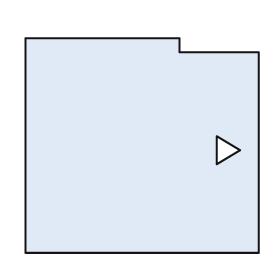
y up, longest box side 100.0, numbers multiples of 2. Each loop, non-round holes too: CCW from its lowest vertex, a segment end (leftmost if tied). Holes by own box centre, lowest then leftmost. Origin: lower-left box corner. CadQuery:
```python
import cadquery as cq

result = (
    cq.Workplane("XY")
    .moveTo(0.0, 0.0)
    .lineTo(100.0, 0.0)
    .lineTo(100.0, 86.0)
    .lineTo(66.0, 86.0)
    .lineTo(66.0, 92.0)
    .lineTo(0.0, 92.0)
    .close()
    .moveTo(82.0, 38.0)
    .lineTo(92.0, 44.0)
    .lineTo(82.0, 50.0)
    .close()
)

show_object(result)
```